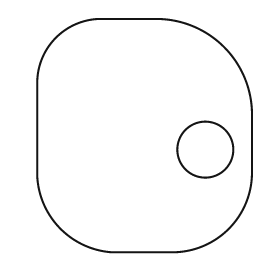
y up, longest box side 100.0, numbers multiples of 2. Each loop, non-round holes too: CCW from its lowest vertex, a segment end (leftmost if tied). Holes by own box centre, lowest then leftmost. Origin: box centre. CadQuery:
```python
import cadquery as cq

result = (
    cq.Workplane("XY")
    .moveTo(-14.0, -50.0)
    .lineTo(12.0, -50.0)
    .threePointArc((36.0, -40.0), (46.0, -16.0))
    .lineTo(46.0, 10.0)
    .threePointArc((34.0, 38.0), (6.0, 50.0))
    .lineTo(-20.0, 50.0)
    .threePointArc((-38.0, 42.0), (-46.0, 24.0))
    .lineTo(-46.0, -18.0)
    .threePointArc((-36.0, -40.0), (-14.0, -50.0))
    .close()
    .moveTo(26.0, -6.0)
    .circle(12.0)
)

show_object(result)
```